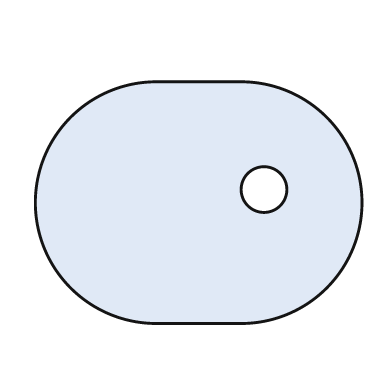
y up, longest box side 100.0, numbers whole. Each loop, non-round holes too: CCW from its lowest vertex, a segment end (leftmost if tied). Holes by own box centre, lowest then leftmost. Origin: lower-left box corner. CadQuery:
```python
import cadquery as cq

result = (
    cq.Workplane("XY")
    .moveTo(37.0, 0.0)
    .lineTo(63.0, 0.0)
    .threePointArc((100.0, 37.0), (63.0, 74.0))
    .lineTo(37.0, 74.0)
    .threePointArc((0.0, 37.0), (37.0, 0.0))
    .close()
    .moveTo(70.0, 41.0)
    .circle(7.0)
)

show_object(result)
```